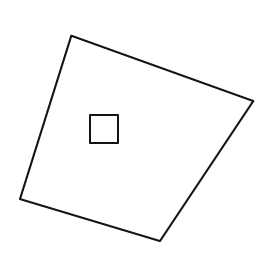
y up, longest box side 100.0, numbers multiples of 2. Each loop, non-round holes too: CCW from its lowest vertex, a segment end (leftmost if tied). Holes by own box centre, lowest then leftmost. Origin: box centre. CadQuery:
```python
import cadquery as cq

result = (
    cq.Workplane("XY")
    .moveTo(10.0, -44.0)
    .lineTo(50.0, 16.0)
    .lineTo(-28.0, 44.0)
    .lineTo(-50.0, -26.0)
    .close()
    .moveTo(-20.0, -2.0)
    .lineTo(-8.0, -2.0)
    .lineTo(-8.0, 10.0)
    .lineTo(-20.0, 10.0)
    .close()
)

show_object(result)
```